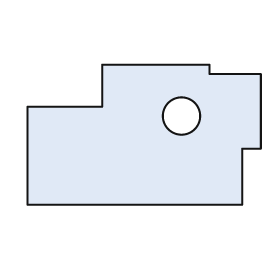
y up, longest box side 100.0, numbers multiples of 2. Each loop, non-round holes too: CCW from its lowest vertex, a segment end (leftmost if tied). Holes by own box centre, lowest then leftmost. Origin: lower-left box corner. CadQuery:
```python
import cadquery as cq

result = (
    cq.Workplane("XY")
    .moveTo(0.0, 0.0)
    .lineTo(92.0, 0.0)
    .lineTo(92.0, 24.0)
    .lineTo(100.0, 24.0)
    .lineTo(100.0, 56.0)
    .lineTo(78.0, 56.0)
    .lineTo(78.0, 60.0)
    .lineTo(32.0, 60.0)
    .lineTo(32.0, 42.0)
    .lineTo(0.0, 42.0)
    .close()
    .moveTo(66.0, 38.0)
    .circle(8.0)
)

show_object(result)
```